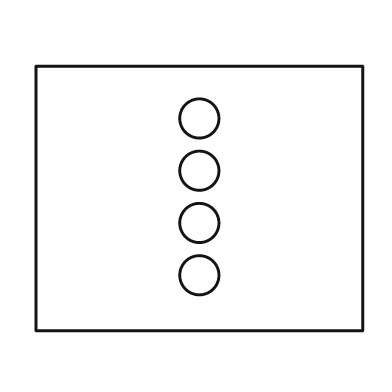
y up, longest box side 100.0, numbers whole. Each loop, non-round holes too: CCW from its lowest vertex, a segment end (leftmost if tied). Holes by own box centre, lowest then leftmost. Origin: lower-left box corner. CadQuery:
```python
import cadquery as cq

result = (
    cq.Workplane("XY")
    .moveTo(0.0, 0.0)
    .lineTo(100.0, 0.0)
    .lineTo(100.0, 81.0)
    .lineTo(0.0, 81.0)
    .close()
    .moveTo(50.0, 17.0)
    .circle(6.0)
    .moveTo(50.0, 33.0)
    .circle(6.0)
    .moveTo(50.0, 49.0)
    .circle(6.0)
    .moveTo(50.0, 65.0)
    .circle(6.0)
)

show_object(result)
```